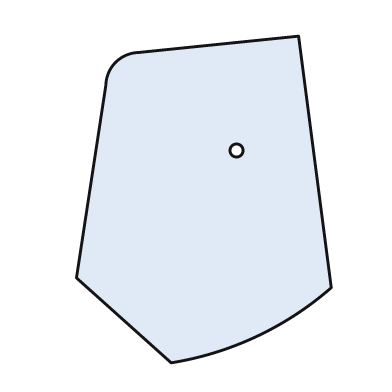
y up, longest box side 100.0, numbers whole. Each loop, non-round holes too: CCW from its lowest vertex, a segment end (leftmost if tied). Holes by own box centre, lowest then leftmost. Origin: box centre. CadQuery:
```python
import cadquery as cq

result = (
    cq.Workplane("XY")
    .moveTo(-10.0, -50.0)
    .threePointArc((16.0, -42.0), (39.0, -27.0))
    .lineTo(29.0, 50.0)
    .lineTo(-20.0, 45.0)
    .threePointArc((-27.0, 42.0), (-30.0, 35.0))
    .lineTo(-39.0, -24.0)
    .close()
    .moveTo(10.0, 15.0)
    .circle(2.0)
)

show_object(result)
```